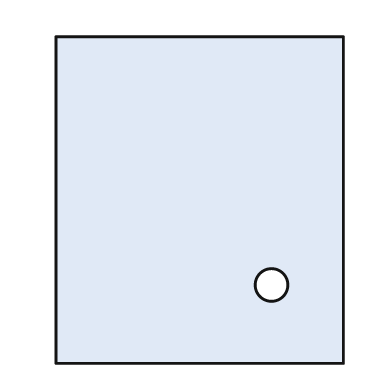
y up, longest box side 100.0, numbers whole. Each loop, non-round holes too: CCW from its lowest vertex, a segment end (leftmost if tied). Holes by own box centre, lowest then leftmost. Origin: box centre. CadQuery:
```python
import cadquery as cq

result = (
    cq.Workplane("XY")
    .moveTo(-44.0, -50.0)
    .lineTo(44.0, -50.0)
    .lineTo(44.0, 50.0)
    .lineTo(-44.0, 50.0)
    .close()
    .moveTo(22.0, -26.0)
    .circle(5.0)
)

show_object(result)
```